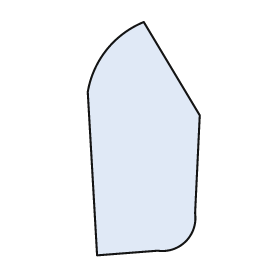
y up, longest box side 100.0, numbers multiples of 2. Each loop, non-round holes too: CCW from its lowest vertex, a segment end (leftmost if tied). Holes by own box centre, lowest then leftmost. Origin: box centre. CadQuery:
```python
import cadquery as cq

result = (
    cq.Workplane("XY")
    .moveTo(-20.0, -50.0)
    .lineTo(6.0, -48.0)
    .threePointArc((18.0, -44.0), (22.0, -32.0))
    .lineTo(24.0, 10.0)
    .lineTo(0.0, 50.0)
    .threePointArc((-16.0, 38.0), (-24.0, 20.0))
    .close()
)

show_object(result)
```